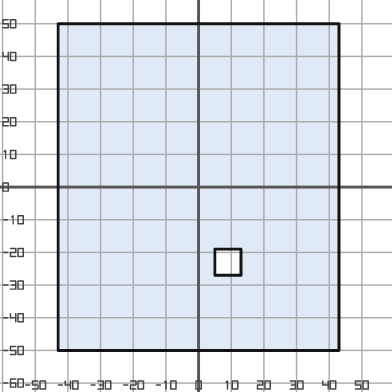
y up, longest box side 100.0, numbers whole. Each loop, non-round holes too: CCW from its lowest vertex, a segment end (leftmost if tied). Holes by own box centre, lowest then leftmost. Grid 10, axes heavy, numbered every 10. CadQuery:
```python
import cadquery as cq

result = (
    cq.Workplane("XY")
    .moveTo(-43.0, -50.0)
    .lineTo(43.0, -50.0)
    .lineTo(43.0, 50.0)
    .lineTo(-43.0, 50.0)
    .close()
    .moveTo(5.0, -27.0)
    .lineTo(13.0, -27.0)
    .lineTo(13.0, -19.0)
    .lineTo(5.0, -19.0)
    .close()
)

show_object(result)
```